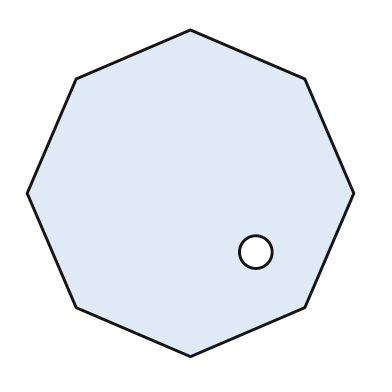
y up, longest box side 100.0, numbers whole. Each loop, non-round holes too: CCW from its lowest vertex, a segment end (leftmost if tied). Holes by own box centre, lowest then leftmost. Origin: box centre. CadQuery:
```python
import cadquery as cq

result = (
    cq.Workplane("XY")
    .moveTo(0.0, -50.0)
    .lineTo(35.0, -35.0)
    .lineTo(50.0, 0.0)
    .lineTo(35.0, 35.0)
    .lineTo(0.0, 50.0)
    .lineTo(-35.0, 35.0)
    .lineTo(-50.0, 0.0)
    .lineTo(-35.0, -35.0)
    .close()
    .moveTo(20.0, -18.0)
    .circle(5.0)
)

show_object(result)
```